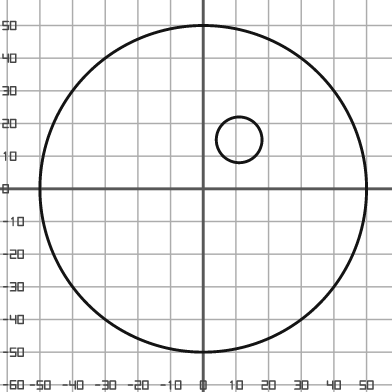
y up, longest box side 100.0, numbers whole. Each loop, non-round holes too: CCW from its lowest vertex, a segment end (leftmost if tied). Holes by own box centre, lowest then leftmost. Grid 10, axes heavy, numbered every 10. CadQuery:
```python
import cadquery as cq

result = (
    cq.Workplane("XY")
    .moveTo(0.0, 0.0)
    .circle(50.0)
    .moveTo(11.0, 15.0)
    .circle(7.0)
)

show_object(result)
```